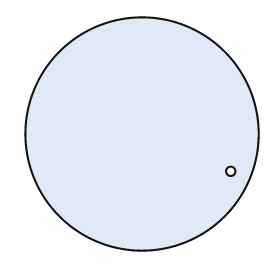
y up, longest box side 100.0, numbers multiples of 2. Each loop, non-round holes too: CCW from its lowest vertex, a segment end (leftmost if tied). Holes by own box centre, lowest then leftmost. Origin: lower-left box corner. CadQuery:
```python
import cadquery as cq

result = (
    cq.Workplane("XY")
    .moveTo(50.0, 50.0)
    .circle(50.0)
    .moveTo(88.0, 34.0)
    .circle(2.0)
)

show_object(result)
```